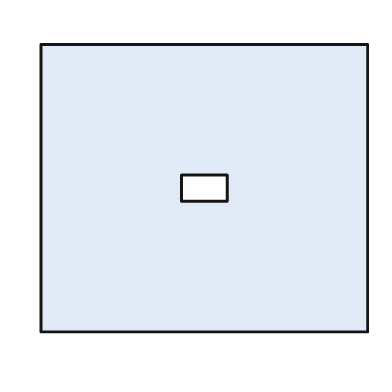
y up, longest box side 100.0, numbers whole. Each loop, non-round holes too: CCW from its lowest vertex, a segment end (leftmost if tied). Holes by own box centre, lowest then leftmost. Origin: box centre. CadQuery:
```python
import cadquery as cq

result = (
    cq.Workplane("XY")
    .moveTo(-50.0, -44.0)
    .lineTo(50.0, -44.0)
    .lineTo(50.0, 44.0)
    .lineTo(-50.0, 44.0)
    .close()
    .moveTo(-7.0, -4.0)
    .lineTo(7.0, -4.0)
    .lineTo(7.0, 4.0)
    .lineTo(-7.0, 4.0)
    .close()
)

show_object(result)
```